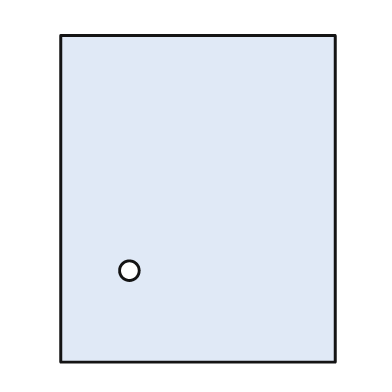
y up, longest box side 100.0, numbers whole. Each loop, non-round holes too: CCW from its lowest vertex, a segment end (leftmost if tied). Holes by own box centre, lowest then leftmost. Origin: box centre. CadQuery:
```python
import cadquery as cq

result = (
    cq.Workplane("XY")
    .moveTo(-42.0, -50.0)
    .lineTo(42.0, -50.0)
    .lineTo(42.0, 50.0)
    .lineTo(-42.0, 50.0)
    .close()
    .moveTo(-21.0, -22.0)
    .circle(3.0)
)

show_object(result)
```